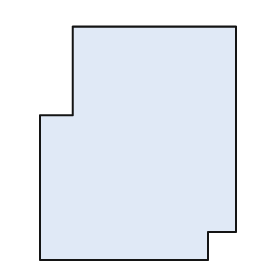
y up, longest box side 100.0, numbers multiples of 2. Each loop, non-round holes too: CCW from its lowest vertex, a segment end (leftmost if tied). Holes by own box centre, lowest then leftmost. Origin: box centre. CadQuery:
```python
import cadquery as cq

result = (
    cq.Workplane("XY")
    .moveTo(-42.0, -50.0)
    .lineTo(30.0, -50.0)
    .lineTo(30.0, -38.0)
    .lineTo(42.0, -38.0)
    .lineTo(42.0, 50.0)
    .lineTo(-28.0, 50.0)
    .lineTo(-28.0, 12.0)
    .lineTo(-42.0, 12.0)
    .close()
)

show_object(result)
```